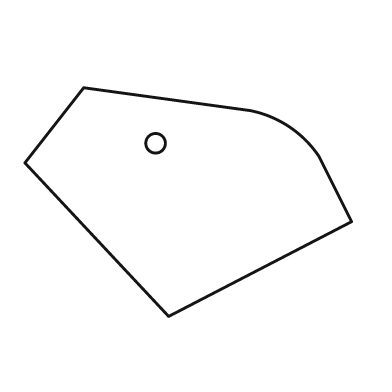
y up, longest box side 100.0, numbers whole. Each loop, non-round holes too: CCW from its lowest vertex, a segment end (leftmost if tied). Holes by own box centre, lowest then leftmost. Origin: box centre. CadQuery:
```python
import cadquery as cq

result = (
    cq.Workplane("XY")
    .moveTo(-6.0, -35.0)
    .lineTo(50.0, -6.0)
    .lineTo(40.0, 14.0)
    .threePointArc((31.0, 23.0), (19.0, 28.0))
    .lineTo(-32.0, 35.0)
    .lineTo(-50.0, 12.0)
    .close()
    .moveTo(-10.0, 18.0)
    .circle(3.0)
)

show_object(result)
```